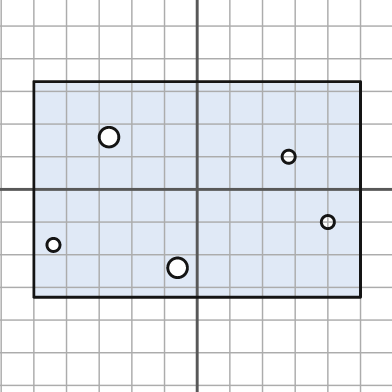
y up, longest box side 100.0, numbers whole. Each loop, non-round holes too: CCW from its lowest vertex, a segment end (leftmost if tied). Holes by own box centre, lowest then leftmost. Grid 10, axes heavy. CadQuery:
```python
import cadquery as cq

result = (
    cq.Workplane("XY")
    .moveTo(-50.0, -33.0)
    .lineTo(50.0, -33.0)
    .lineTo(50.0, 33.0)
    .lineTo(-50.0, 33.0)
    .close()
    .moveTo(-6.0, -24.0)
    .circle(3.0)
    .moveTo(-44.0, -17.0)
    .circle(2.0)
    .moveTo(40.0, -10.0)
    .circle(2.0)
    .moveTo(28.0, 10.0)
    .circle(2.0)
    .moveTo(-27.0, 16.0)
    .circle(3.0)
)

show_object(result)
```